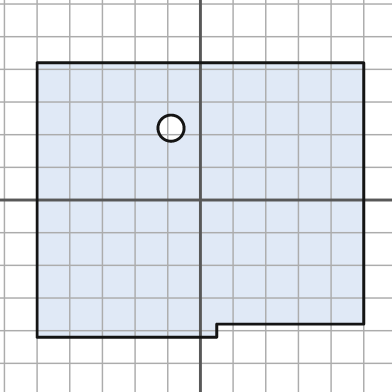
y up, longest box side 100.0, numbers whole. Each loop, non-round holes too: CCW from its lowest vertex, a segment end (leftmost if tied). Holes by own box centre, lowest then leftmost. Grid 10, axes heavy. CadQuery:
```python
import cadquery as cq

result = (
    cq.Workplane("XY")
    .moveTo(-50.0, -42.0)
    .lineTo(5.0, -42.0)
    .lineTo(5.0, -38.0)
    .lineTo(50.0, -38.0)
    .lineTo(50.0, 42.0)
    .lineTo(-50.0, 42.0)
    .close()
    .moveTo(-9.0, 22.0)
    .circle(4.0)
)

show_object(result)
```